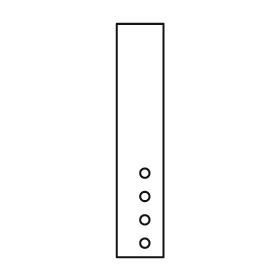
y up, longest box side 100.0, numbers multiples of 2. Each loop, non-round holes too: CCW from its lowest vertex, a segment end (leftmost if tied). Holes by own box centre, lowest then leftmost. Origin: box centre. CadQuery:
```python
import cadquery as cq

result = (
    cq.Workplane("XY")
    .moveTo(-10.0, -50.0)
    .lineTo(10.0, -50.0)
    .lineTo(10.0, 50.0)
    .lineTo(-10.0, 50.0)
    .close()
    .moveTo(2.0, -44.0)
    .circle(2.0)
    .moveTo(2.0, -34.0)
    .circle(2.0)
    .moveTo(2.0, -24.0)
    .circle(2.0)
    .moveTo(2.0, -14.0)
    .circle(2.0)
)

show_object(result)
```